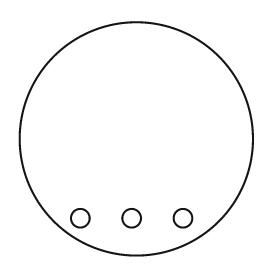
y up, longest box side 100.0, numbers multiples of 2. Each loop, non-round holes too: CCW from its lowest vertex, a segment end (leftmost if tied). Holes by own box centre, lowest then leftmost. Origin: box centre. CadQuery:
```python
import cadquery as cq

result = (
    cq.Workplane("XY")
    .moveTo(0.0, 0.0)
    .circle(50.0)
    .moveTo(-24.0, -34.0)
    .circle(4.0)
    .moveTo(-2.0, -34.0)
    .circle(4.0)
    .moveTo(20.0, -34.0)
    .circle(4.0)
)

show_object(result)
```